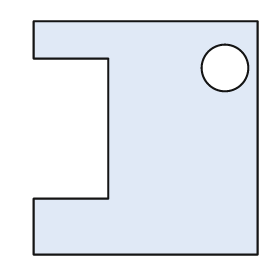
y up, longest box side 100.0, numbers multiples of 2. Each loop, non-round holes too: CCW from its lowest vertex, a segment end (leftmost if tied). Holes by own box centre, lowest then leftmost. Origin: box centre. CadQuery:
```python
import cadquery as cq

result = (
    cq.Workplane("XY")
    .moveTo(-48.0, -50.0)
    .lineTo(48.0, -50.0)
    .lineTo(48.0, 50.0)
    .lineTo(-48.0, 50.0)
    .lineTo(-48.0, 34.0)
    .lineTo(-16.0, 34.0)
    .lineTo(-16.0, -26.0)
    .lineTo(-48.0, -26.0)
    .close()
    .moveTo(34.0, 30.0)
    .circle(10.0)
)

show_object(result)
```